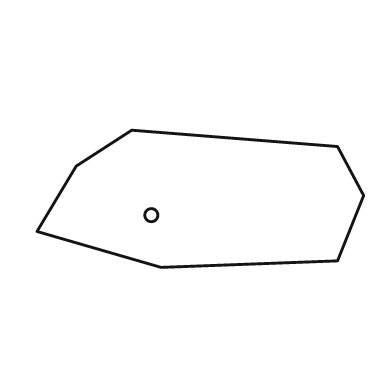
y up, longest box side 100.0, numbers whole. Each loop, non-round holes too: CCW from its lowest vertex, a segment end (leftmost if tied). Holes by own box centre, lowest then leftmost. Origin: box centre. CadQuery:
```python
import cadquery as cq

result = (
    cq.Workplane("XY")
    .moveTo(-12.0, -21.0)
    .lineTo(42.0, -19.0)
    .lineTo(50.0, 1.0)
    .lineTo(42.0, 16.0)
    .lineTo(-21.0, 21.0)
    .lineTo(-38.0, 10.0)
    .lineTo(-50.0, -10.0)
    .close()
    .moveTo(-15.0, -5.0)
    .circle(2.0)
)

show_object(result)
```